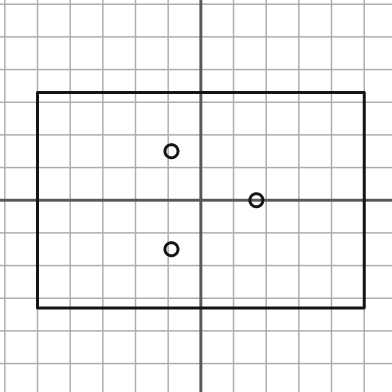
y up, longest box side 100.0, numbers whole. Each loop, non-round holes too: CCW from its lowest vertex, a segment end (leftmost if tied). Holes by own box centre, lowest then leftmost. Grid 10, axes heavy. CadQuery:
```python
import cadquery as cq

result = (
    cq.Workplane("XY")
    .moveTo(-50.0, -33.0)
    .lineTo(50.0, -33.0)
    .lineTo(50.0, 33.0)
    .lineTo(-50.0, 33.0)
    .close()
    .moveTo(-9.0, -15.0)
    .circle(2.0)
    .moveTo(17.0, 0.0)
    .circle(2.0)
    .moveTo(-9.0, 15.0)
    .circle(2.0)
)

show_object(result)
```